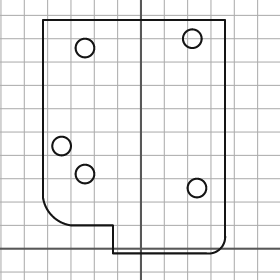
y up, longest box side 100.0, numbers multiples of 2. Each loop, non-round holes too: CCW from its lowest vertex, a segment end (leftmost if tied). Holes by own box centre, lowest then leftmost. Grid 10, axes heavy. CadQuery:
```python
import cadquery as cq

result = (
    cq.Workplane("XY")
    .moveTo(-12.0, -2.0)
    .lineTo(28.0, -2.0)
    .threePointArc((34.0, 0.0), (36.0, 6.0))
    .lineTo(36.0, 98.0)
    .lineTo(-42.0, 98.0)
    .lineTo(-42.0, 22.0)
    .threePointArc((-38.0, 14.0), (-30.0, 10.0))
    .lineTo(-12.0, 10.0)
    .close()
    .moveTo(24.0, 26.0)
    .circle(4.0)
    .moveTo(-24.0, 32.0)
    .circle(4.0)
    .moveTo(-34.0, 44.0)
    .circle(4.0)
    .moveTo(-24.0, 86.0)
    .circle(4.0)
    .moveTo(22.0, 90.0)
    .circle(4.0)
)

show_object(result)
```